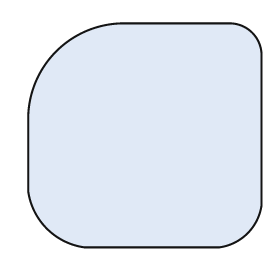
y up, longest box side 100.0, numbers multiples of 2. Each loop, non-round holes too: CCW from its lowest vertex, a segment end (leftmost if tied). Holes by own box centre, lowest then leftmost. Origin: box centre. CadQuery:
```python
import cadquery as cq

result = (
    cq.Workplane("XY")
    .moveTo(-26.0, -48.0)
    .lineTo(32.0, -48.0)
    .threePointArc((44.0, -42.0), (50.0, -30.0))
    .lineTo(50.0, 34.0)
    .threePointArc((46.0, 44.0), (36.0, 48.0))
    .lineTo(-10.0, 48.0)
    .threePointArc((-38.0, 36.0), (-50.0, 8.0))
    .lineTo(-50.0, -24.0)
    .threePointArc((-42.0, -40.0), (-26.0, -48.0))
    .close()
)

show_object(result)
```